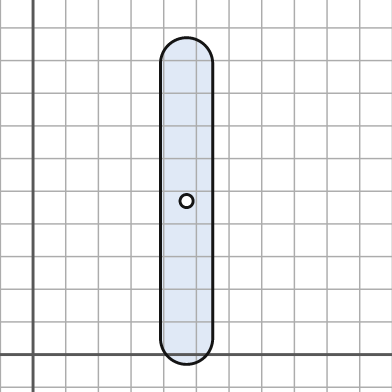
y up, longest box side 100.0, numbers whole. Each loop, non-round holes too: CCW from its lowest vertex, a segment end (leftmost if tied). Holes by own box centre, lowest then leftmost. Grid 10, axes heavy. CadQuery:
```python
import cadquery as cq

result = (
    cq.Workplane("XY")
    .moveTo(39.0, 5.0)
    .threePointArc((47.0, -3.0), (55.0, 5.0))
    .lineTo(55.0, 89.0)
    .threePointArc((47.0, 97.0), (39.0, 89.0))
    .close()
    .moveTo(47.0, 47.0)
    .circle(2.0)
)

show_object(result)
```